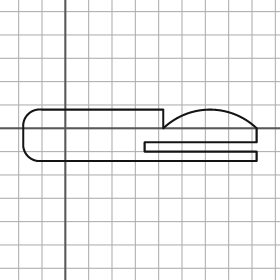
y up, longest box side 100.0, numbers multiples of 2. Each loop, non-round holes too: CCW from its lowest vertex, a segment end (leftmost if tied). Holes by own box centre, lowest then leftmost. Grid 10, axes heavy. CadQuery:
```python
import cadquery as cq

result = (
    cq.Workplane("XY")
    .moveTo(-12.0, -14.0)
    .lineTo(82.0, -14.0)
    .lineTo(82.0, -10.0)
    .lineTo(34.0, -10.0)
    .lineTo(34.0, -6.0)
    .lineTo(82.0, -6.0)
    .lineTo(82.0, 0.0)
    .threePointArc((62.0, 8.0), (42.0, 0.0))
    .lineTo(42.0, 8.0)
    .lineTo(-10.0, 8.0)
    .threePointArc((-16.0, 6.0), (-18.0, 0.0))
    .lineTo(-18.0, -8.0)
    .threePointArc((-16.0, -12.0), (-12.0, -14.0))
    .close()
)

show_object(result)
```